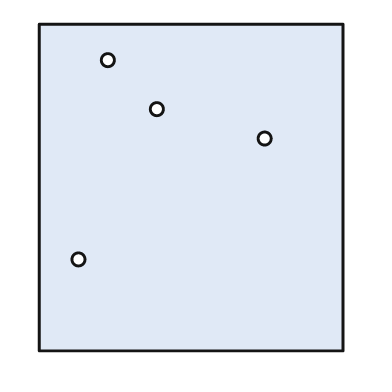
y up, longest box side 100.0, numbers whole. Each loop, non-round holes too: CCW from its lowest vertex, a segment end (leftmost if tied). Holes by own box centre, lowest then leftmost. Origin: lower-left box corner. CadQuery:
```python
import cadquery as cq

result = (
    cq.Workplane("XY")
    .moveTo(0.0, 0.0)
    .lineTo(93.0, 0.0)
    .lineTo(93.0, 100.0)
    .lineTo(0.0, 100.0)
    .close()
    .moveTo(12.0, 28.0)
    .circle(2.0)
    .moveTo(69.0, 65.0)
    .circle(2.0)
    .moveTo(36.0, 74.0)
    .circle(2.0)
    .moveTo(21.0, 89.0)
    .circle(2.0)
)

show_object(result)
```